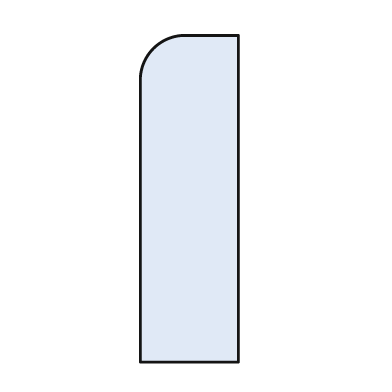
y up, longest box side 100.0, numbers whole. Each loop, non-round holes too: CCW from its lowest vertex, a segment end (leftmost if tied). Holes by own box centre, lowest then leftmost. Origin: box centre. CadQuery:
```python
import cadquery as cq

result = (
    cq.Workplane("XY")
    .moveTo(-15.0, -50.0)
    .lineTo(15.0, -50.0)
    .lineTo(15.0, 50.0)
    .lineTo(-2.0, 50.0)
    .threePointArc((-11.0, 46.0), (-15.0, 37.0))
    .close()
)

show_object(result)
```